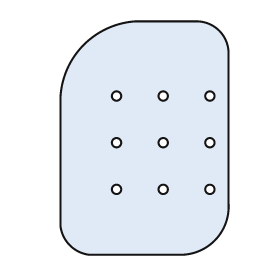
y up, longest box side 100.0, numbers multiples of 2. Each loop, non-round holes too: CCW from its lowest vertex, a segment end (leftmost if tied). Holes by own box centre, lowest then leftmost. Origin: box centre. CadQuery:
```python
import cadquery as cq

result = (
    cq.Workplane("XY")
    .moveTo(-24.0, -50.0)
    .lineTo(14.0, -50.0)
    .threePointArc((30.0, -44.0), (36.0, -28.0))
    .lineTo(36.0, 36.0)
    .threePointArc((32.0, 46.0), (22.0, 50.0))
    .lineTo(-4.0, 50.0)
    .threePointArc((-26.0, 40.0), (-36.0, 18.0))
    .lineTo(-36.0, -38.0)
    .threePointArc((-32.0, -46.0), (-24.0, -50.0))
    .close()
    .moveTo(-12.0, -22.0)
    .circle(2.0)
    .moveTo(8.0, -22.0)
    .circle(2.0)
    .moveTo(28.0, -22.0)
    .circle(2.0)
    .moveTo(-12.0, -2.0)
    .circle(2.0)
    .moveTo(8.0, -2.0)
    .circle(2.0)
    .moveTo(28.0, -2.0)
    .circle(2.0)
    .moveTo(-12.0, 18.0)
    .circle(2.0)
    .moveTo(8.0, 18.0)
    .circle(2.0)
    .moveTo(28.0, 18.0)
    .circle(2.0)
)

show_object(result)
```